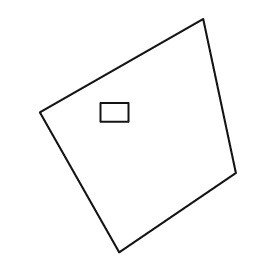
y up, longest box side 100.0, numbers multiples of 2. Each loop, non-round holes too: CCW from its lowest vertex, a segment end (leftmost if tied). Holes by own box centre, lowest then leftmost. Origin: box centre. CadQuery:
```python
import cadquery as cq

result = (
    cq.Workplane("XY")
    .moveTo(-8.0, -50.0)
    .lineTo(42.0, -16.0)
    .lineTo(28.0, 50.0)
    .lineTo(-42.0, 10.0)
    .close()
    .moveTo(-16.0, 6.0)
    .lineTo(-4.0, 6.0)
    .lineTo(-4.0, 14.0)
    .lineTo(-16.0, 14.0)
    .close()
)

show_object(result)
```